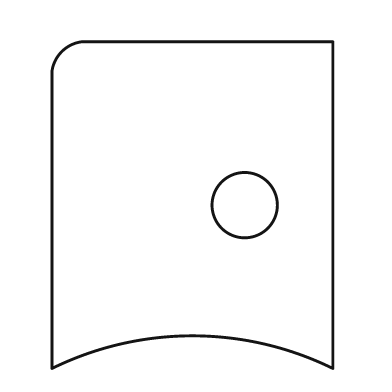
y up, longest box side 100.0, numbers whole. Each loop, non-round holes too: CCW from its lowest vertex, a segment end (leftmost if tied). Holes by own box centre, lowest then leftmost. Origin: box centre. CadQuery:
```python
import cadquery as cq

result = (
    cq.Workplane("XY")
    .moveTo(-43.0, -50.0)
    .threePointArc((0.0, -40.0), (43.0, -50.0))
    .lineTo(43.0, 50.0)
    .lineTo(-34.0, 50.0)
    .threePointArc((-40.0, 47.0), (-43.0, 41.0))
    .close()
    .moveTo(16.0, 0.0)
    .circle(10.0)
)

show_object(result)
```